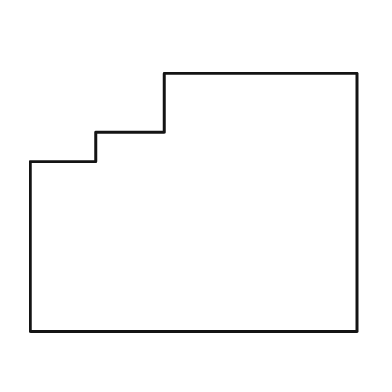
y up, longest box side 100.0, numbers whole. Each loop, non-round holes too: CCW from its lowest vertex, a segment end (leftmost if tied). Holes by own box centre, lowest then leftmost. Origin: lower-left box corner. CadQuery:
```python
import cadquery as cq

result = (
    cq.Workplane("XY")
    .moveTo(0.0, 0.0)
    .lineTo(100.0, 0.0)
    .lineTo(100.0, 79.0)
    .lineTo(41.0, 79.0)
    .lineTo(41.0, 61.0)
    .lineTo(20.0, 61.0)
    .lineTo(20.0, 52.0)
    .lineTo(0.0, 52.0)
    .close()
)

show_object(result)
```